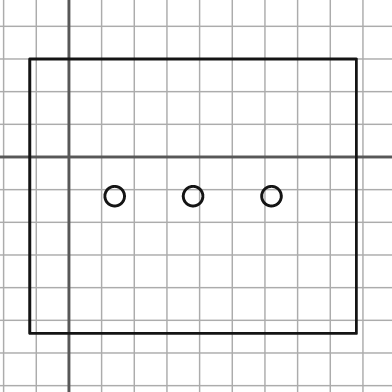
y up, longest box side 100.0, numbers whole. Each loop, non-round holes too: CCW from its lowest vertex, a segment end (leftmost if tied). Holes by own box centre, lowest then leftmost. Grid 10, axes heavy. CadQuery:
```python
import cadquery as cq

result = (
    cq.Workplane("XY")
    .moveTo(-12.0, -54.0)
    .lineTo(88.0, -54.0)
    .lineTo(88.0, 30.0)
    .lineTo(-12.0, 30.0)
    .close()
    .moveTo(14.0, -12.0)
    .circle(3.0)
    .moveTo(38.0, -12.0)
    .circle(3.0)
    .moveTo(62.0, -12.0)
    .circle(3.0)
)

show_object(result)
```